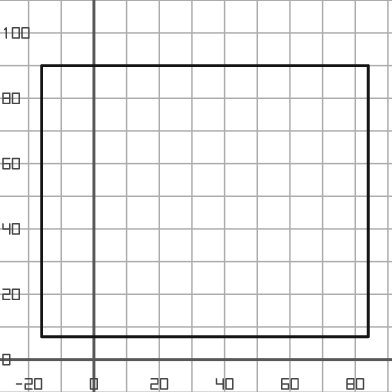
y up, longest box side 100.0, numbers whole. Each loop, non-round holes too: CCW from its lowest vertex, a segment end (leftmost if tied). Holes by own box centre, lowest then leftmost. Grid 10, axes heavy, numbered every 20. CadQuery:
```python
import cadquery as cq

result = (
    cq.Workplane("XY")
    .moveTo(-16.0, 7.0)
    .lineTo(84.0, 7.0)
    .lineTo(84.0, 90.0)
    .lineTo(-16.0, 90.0)
    .close()
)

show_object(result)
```